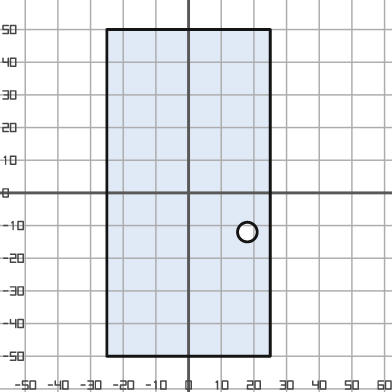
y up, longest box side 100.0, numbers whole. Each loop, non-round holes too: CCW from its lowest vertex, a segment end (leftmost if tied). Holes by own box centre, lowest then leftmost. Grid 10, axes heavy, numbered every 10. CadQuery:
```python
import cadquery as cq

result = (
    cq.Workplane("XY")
    .moveTo(-25.0, -50.0)
    .lineTo(25.0, -50.0)
    .lineTo(25.0, 50.0)
    .lineTo(-25.0, 50.0)
    .close()
    .moveTo(18.0, -12.0)
    .circle(3.0)
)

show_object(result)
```